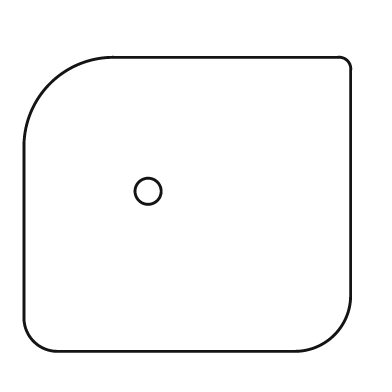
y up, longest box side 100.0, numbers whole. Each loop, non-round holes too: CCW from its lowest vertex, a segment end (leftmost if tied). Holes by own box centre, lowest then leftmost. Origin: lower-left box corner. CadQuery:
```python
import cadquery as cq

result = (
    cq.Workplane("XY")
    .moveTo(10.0, 0.0)
    .lineTo(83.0, 0.0)
    .threePointArc((95.0, 5.0), (100.0, 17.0))
    .lineTo(100.0, 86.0)
    .threePointArc((99.0, 89.0), (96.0, 90.0))
    .lineTo(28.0, 90.0)
    .threePointArc((8.0, 82.0), (0.0, 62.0))
    .lineTo(0.0, 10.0)
    .threePointArc((3.0, 3.0), (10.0, 0.0))
    .close()
    .moveTo(38.0, 49.0)
    .circle(4.0)
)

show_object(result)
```